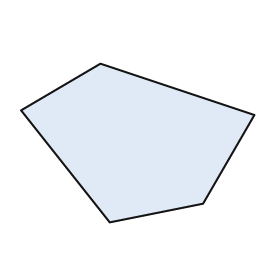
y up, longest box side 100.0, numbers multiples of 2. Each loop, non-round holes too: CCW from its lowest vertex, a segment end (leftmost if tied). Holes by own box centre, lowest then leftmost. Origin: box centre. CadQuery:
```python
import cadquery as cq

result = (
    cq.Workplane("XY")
    .moveTo(-12.0, -34.0)
    .lineTo(28.0, -26.0)
    .lineTo(50.0, 12.0)
    .lineTo(-16.0, 34.0)
    .lineTo(-50.0, 14.0)
    .close()
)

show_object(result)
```